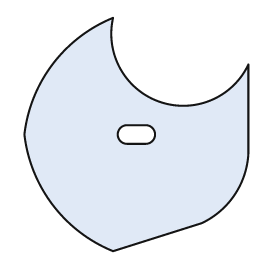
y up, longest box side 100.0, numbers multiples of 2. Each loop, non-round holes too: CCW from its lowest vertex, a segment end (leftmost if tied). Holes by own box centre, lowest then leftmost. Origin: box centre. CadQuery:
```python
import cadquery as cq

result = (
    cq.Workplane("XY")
    .moveTo(-10.0, -50.0)
    .lineTo(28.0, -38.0)
    .threePointArc((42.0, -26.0), (48.0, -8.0))
    .lineTo(48.0, 30.0)
    .threePointArc((10.0, 14.0), (-10.0, 50.0))
    .threePointArc((-36.0, 30.0), (-48.0, 0.0))
    .threePointArc((-36.0, -30.0), (-10.0, -50.0))
    .close()
    .moveTo(-4.0, -4.0)
    .lineTo(4.0, -4.0)
    .threePointArc((8.0, 0.0), (4.0, 4.0))
    .lineTo(-4.0, 4.0)
    .threePointArc((-8.0, 0.0), (-4.0, -4.0))
    .close()
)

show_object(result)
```